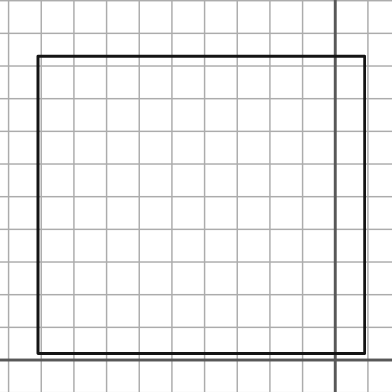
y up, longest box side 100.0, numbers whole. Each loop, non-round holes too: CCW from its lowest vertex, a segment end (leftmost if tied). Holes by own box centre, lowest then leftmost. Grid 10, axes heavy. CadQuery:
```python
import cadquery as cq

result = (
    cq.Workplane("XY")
    .moveTo(-91.0, 2.0)
    .lineTo(9.0, 2.0)
    .lineTo(9.0, 93.0)
    .lineTo(-91.0, 93.0)
    .close()
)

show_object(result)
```